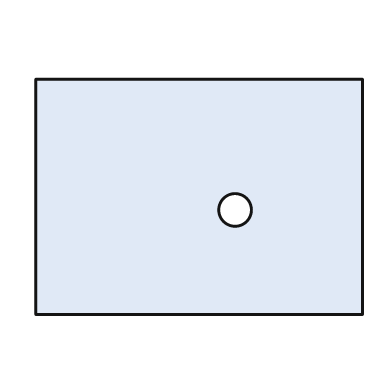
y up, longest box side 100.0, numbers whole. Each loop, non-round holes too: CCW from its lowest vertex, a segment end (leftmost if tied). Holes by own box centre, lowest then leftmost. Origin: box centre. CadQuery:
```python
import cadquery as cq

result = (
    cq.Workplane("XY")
    .moveTo(-50.0, -36.0)
    .lineTo(50.0, -36.0)
    .lineTo(50.0, 36.0)
    .lineTo(-50.0, 36.0)
    .close()
    .moveTo(11.0, -4.0)
    .circle(5.0)
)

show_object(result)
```